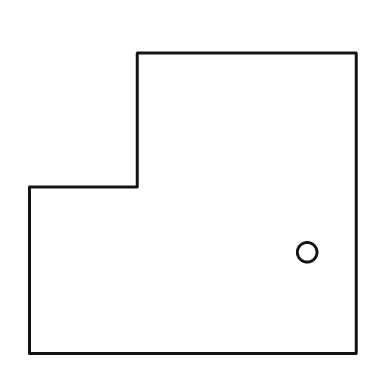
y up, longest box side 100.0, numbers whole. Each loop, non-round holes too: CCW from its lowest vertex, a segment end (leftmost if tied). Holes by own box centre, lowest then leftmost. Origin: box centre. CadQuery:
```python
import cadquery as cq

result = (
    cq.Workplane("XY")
    .moveTo(-50.0, -46.0)
    .lineTo(50.0, -46.0)
    .lineTo(50.0, 46.0)
    .lineTo(-17.0, 46.0)
    .lineTo(-17.0, 5.0)
    .lineTo(-50.0, 5.0)
    .close()
    .moveTo(35.0, -15.0)
    .circle(3.0)
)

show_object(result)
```